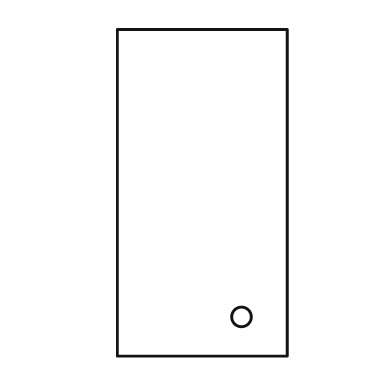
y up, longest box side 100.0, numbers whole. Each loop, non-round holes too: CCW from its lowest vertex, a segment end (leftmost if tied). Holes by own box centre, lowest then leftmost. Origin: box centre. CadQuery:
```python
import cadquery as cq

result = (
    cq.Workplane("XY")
    .moveTo(-26.0, -50.0)
    .lineTo(26.0, -50.0)
    .lineTo(26.0, 50.0)
    .lineTo(-26.0, 50.0)
    .close()
    .moveTo(12.0, -38.0)
    .circle(3.0)
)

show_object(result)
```